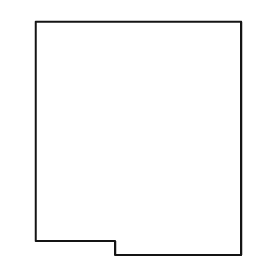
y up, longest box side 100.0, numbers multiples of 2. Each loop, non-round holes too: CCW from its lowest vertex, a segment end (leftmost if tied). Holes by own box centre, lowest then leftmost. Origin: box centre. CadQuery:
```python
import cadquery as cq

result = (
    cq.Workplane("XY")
    .moveTo(-10.0, -50.0)
    .lineTo(44.0, -50.0)
    .lineTo(44.0, 50.0)
    .lineTo(-44.0, 50.0)
    .lineTo(-44.0, -44.0)
    .lineTo(-10.0, -44.0)
    .close()
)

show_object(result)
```